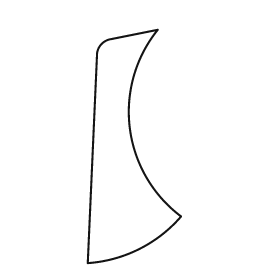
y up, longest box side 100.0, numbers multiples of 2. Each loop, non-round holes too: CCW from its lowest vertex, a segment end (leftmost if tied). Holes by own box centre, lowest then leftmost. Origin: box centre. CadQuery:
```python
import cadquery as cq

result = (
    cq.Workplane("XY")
    .moveTo(-20.0, -50.0)
    .threePointArc((2.0, -44.0), (20.0, -30.0))
    .threePointArc((-2.0, 8.0), (10.0, 50.0))
    .lineTo(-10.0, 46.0)
    .threePointArc((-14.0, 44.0), (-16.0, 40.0))
    .close()
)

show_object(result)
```